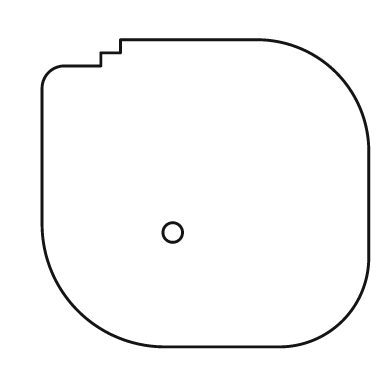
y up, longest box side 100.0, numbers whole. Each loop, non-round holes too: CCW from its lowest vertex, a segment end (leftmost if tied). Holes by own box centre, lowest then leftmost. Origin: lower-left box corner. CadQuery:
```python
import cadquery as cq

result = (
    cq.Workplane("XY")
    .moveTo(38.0, 0.0)
    .lineTo(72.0, 0.0)
    .threePointArc((92.0, 8.0), (100.0, 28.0))
    .lineTo(100.0, 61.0)
    .threePointArc((90.0, 84.0), (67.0, 94.0))
    .lineTo(24.0, 94.0)
    .lineTo(24.0, 90.0)
    .lineTo(18.0, 90.0)
    .lineTo(18.0, 86.0)
    .lineTo(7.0, 86.0)
    .threePointArc((2.0, 84.0), (0.0, 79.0))
    .lineTo(0.0, 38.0)
    .threePointArc((11.0, 11.0), (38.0, 0.0))
    .close()
    .moveTo(40.0, 35.0)
    .circle(3.0)
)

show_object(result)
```